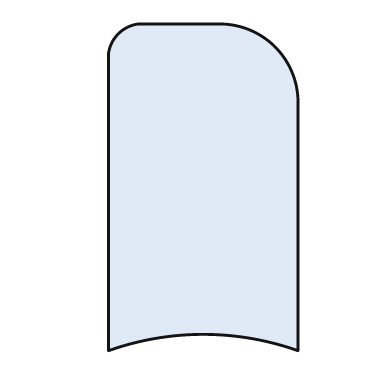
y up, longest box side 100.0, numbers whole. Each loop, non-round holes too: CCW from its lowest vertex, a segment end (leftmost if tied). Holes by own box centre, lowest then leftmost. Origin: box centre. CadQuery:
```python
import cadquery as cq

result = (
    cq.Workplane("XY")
    .moveTo(-29.0, -50.0)
    .threePointArc((0.0, -45.0), (29.0, -50.0))
    .lineTo(29.0, 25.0)
    .threePointArc((22.0, 43.0), (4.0, 50.0))
    .lineTo(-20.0, 50.0)
    .threePointArc((-26.0, 47.0), (-29.0, 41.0))
    .close()
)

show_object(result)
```